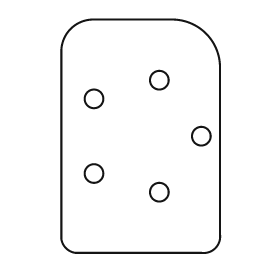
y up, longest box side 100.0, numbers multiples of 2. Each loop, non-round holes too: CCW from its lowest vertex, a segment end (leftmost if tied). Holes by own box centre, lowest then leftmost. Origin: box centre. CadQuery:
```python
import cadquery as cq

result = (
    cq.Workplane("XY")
    .moveTo(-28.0, -50.0)
    .lineTo(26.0, -50.0)
    .threePointArc((32.0, -48.0), (34.0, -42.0))
    .lineTo(34.0, 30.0)
    .threePointArc((28.0, 44.0), (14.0, 50.0))
    .lineTo(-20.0, 50.0)
    .threePointArc((-30.0, 46.0), (-34.0, 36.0))
    .lineTo(-34.0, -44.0)
    .threePointArc((-32.0, -48.0), (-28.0, -50.0))
    .close()
    .moveTo(8.0, -24.0)
    .circle(4.0)
    .moveTo(-20.0, -16.0)
    .circle(4.0)
    .moveTo(26.0, 0.0)
    .circle(4.0)
    .moveTo(-20.0, 16.0)
    .circle(4.0)
    .moveTo(8.0, 24.0)
    .circle(4.0)
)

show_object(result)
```